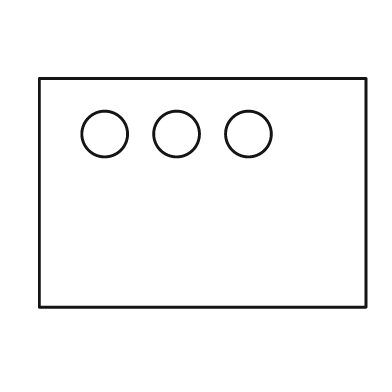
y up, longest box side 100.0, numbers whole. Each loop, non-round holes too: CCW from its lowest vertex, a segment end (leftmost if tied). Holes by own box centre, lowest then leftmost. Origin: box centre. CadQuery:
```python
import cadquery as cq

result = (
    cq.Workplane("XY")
    .moveTo(-50.0, -35.0)
    .lineTo(50.0, -35.0)
    .lineTo(50.0, 35.0)
    .lineTo(-50.0, 35.0)
    .close()
    .moveTo(-30.0, 18.0)
    .circle(7.0)
    .moveTo(-8.0, 18.0)
    .circle(7.0)
    .moveTo(14.0, 18.0)
    .circle(7.0)
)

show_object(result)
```